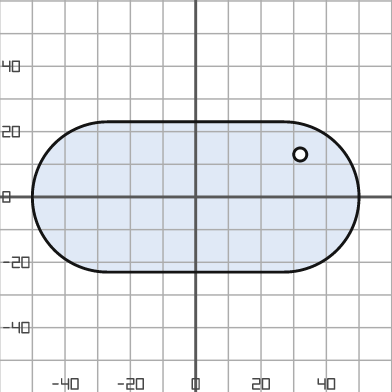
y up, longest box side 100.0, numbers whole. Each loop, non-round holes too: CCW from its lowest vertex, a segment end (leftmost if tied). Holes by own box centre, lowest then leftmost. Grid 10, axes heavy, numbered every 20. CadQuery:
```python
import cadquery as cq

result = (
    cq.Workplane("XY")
    .moveTo(-27.0, -23.0)
    .lineTo(27.0, -23.0)
    .threePointArc((50.0, 0.0), (27.0, 23.0))
    .lineTo(-27.0, 23.0)
    .threePointArc((-50.0, 0.0), (-27.0, -23.0))
    .close()
    .moveTo(32.0, 13.0)
    .circle(2.0)
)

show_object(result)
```